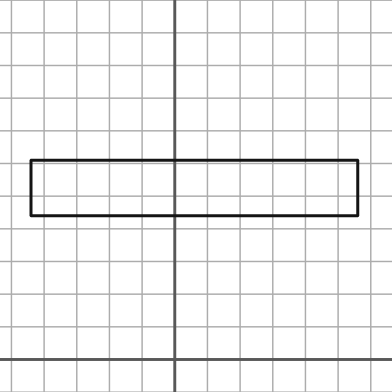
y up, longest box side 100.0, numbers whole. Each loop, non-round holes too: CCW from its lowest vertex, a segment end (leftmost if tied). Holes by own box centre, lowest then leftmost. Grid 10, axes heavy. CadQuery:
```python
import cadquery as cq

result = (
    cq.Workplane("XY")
    .moveTo(-44.0, 44.0)
    .lineTo(56.0, 44.0)
    .lineTo(56.0, 61.0)
    .lineTo(-44.0, 61.0)
    .close()
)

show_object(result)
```